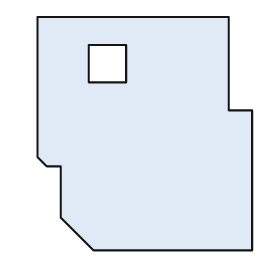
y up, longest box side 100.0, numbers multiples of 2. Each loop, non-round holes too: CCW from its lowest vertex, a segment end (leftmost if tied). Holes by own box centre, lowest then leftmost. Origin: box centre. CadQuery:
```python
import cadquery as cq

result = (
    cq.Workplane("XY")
    .moveTo(-22.0, -50.0)
    .lineTo(46.0, -50.0)
    .lineTo(46.0, 10.0)
    .lineTo(36.0, 10.0)
    .lineTo(36.0, 50.0)
    .lineTo(-46.0, 50.0)
    .lineTo(-46.0, -10.0)
    .lineTo(-42.0, -14.0)
    .lineTo(-36.0, -14.0)
    .lineTo(-36.0, -36.0)
    .close()
    .moveTo(-24.0, 22.0)
    .lineTo(-8.0, 22.0)
    .lineTo(-8.0, 38.0)
    .lineTo(-24.0, 38.0)
    .close()
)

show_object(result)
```